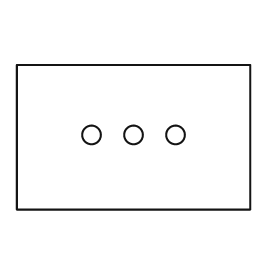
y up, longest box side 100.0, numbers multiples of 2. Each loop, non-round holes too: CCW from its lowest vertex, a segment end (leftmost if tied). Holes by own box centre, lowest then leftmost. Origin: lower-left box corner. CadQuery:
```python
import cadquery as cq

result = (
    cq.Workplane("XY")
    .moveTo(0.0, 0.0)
    .lineTo(100.0, 0.0)
    .lineTo(100.0, 62.0)
    .lineTo(0.0, 62.0)
    .close()
    .moveTo(32.0, 32.0)
    .circle(4.0)
    .moveTo(50.0, 32.0)
    .circle(4.0)
    .moveTo(68.0, 32.0)
    .circle(4.0)
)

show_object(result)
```